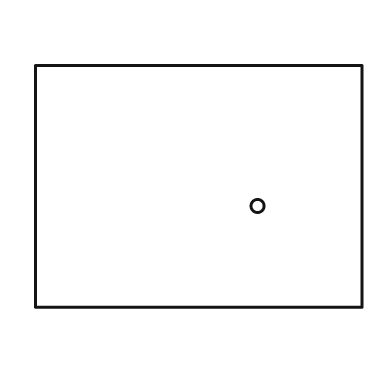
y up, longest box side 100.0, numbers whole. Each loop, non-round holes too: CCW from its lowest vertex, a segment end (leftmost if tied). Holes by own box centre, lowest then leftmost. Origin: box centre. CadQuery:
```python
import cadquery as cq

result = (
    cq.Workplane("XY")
    .moveTo(-50.0, -37.0)
    .lineTo(50.0, -37.0)
    .lineTo(50.0, 37.0)
    .lineTo(-50.0, 37.0)
    .close()
    .moveTo(18.0, -6.0)
    .circle(2.0)
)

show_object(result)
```